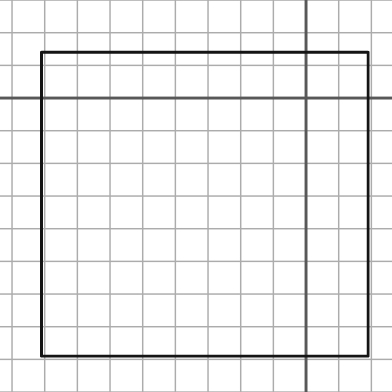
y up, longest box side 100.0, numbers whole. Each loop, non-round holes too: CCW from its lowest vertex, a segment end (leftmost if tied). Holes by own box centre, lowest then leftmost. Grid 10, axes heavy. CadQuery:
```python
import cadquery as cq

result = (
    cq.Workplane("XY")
    .moveTo(-81.0, -79.0)
    .lineTo(19.0, -79.0)
    .lineTo(19.0, 14.0)
    .lineTo(-81.0, 14.0)
    .close()
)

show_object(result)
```